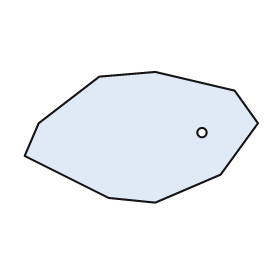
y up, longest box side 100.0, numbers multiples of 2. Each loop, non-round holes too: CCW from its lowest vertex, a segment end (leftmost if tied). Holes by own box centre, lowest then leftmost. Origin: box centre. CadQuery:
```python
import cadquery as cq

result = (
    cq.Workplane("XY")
    .moveTo(6.0, -28.0)
    .lineTo(34.0, -16.0)
    .lineTo(50.0, 6.0)
    .lineTo(40.0, 20.0)
    .lineTo(6.0, 28.0)
    .lineTo(-18.0, 26.0)
    .lineTo(-44.0, 6.0)
    .lineTo(-50.0, -8.0)
    .lineTo(-14.0, -26.0)
    .close()
    .moveTo(26.0, 2.0)
    .circle(2.0)
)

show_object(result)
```